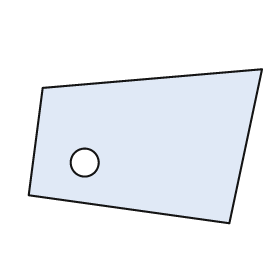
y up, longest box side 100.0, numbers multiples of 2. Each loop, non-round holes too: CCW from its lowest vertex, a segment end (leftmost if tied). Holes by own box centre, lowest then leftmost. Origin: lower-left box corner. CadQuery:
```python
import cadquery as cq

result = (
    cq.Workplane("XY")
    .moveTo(86.0, 0.0)
    .lineTo(100.0, 66.0)
    .lineTo(6.0, 58.0)
    .lineTo(0.0, 12.0)
    .close()
    .moveTo(24.0, 26.0)
    .circle(6.0)
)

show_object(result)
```